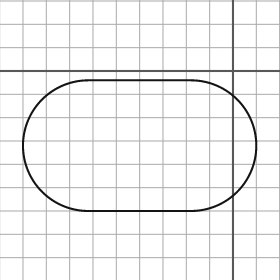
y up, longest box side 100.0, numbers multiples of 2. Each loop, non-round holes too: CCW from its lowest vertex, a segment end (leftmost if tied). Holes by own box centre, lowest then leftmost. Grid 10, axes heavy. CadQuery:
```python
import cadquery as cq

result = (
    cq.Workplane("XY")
    .moveTo(-62.0, -60.0)
    .lineTo(-18.0, -60.0)
    .threePointArc((10.0, -32.0), (-18.0, -4.0))
    .lineTo(-62.0, -4.0)
    .threePointArc((-90.0, -32.0), (-62.0, -60.0))
    .close()
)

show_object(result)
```